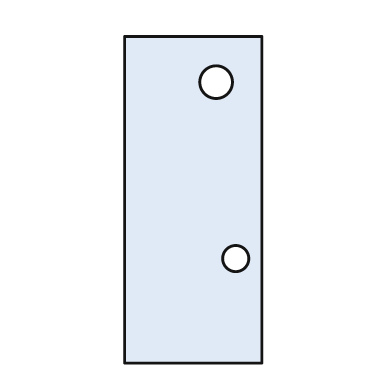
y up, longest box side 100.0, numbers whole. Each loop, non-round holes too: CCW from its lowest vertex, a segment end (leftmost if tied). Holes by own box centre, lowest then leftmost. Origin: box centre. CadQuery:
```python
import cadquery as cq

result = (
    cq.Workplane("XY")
    .moveTo(-21.0, -50.0)
    .lineTo(21.0, -50.0)
    .lineTo(21.0, 50.0)
    .lineTo(-21.0, 50.0)
    .close()
    .moveTo(13.0, -18.0)
    .circle(4.0)
    .moveTo(7.0, 36.0)
    .circle(5.0)
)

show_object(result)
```